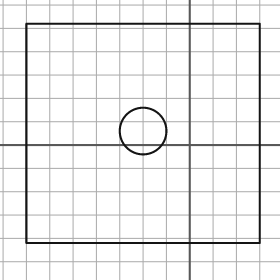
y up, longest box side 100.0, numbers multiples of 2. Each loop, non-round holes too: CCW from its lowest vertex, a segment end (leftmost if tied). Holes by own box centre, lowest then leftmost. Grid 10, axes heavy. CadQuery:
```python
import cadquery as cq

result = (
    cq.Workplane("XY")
    .moveTo(-70.0, -42.0)
    .lineTo(30.0, -42.0)
    .lineTo(30.0, 52.0)
    .lineTo(-70.0, 52.0)
    .close()
    .moveTo(-20.0, 6.0)
    .circle(10.0)
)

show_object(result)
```